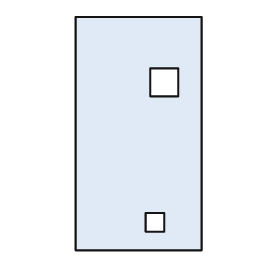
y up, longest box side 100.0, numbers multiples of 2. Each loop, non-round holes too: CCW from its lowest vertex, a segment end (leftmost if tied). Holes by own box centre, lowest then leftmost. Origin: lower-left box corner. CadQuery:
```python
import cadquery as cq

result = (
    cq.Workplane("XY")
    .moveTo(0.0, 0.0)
    .lineTo(54.0, 0.0)
    .lineTo(54.0, 100.0)
    .lineTo(0.0, 100.0)
    .close()
    .moveTo(30.0, 8.0)
    .lineTo(38.0, 8.0)
    .lineTo(38.0, 16.0)
    .lineTo(30.0, 16.0)
    .close()
    .moveTo(32.0, 66.0)
    .lineTo(44.0, 66.0)
    .lineTo(44.0, 78.0)
    .lineTo(32.0, 78.0)
    .close()
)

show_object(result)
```